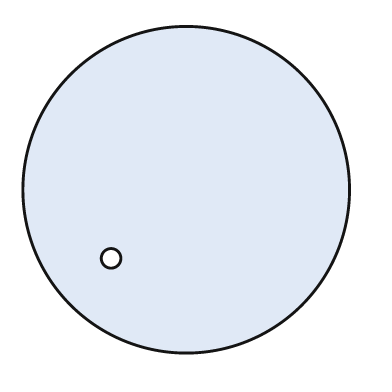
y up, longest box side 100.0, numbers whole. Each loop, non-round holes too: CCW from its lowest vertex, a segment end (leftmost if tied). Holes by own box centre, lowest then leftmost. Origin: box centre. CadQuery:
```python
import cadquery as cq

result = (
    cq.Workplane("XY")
    .moveTo(0.0, 0.0)
    .circle(50.0)
    .moveTo(-23.0, -21.0)
    .circle(3.0)
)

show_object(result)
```